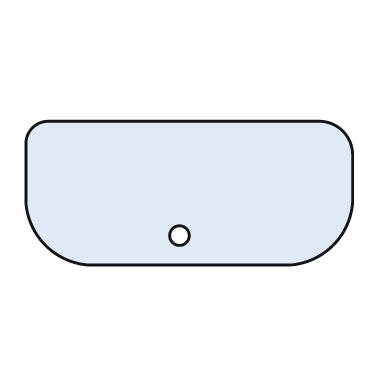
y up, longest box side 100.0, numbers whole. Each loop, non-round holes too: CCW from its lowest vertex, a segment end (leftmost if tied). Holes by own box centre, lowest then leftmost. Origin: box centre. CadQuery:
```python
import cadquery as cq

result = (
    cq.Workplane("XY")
    .moveTo(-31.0, -22.0)
    .lineTo(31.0, -22.0)
    .threePointArc((44.0, -16.0), (50.0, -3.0))
    .lineTo(50.0, 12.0)
    .threePointArc((47.0, 19.0), (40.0, 22.0))
    .lineTo(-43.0, 22.0)
    .threePointArc((-48.0, 20.0), (-50.0, 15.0))
    .lineTo(-50.0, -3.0)
    .threePointArc((-44.0, -16.0), (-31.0, -22.0))
    .close()
    .moveTo(-3.0, -13.0)
    .circle(3.0)
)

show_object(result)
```